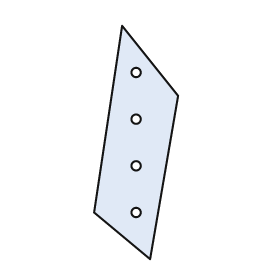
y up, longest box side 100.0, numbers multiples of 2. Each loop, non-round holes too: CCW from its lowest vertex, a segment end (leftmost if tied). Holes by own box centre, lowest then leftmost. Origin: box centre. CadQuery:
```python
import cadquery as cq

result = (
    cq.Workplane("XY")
    .moveTo(6.0, -50.0)
    .lineTo(18.0, 20.0)
    .lineTo(-6.0, 50.0)
    .lineTo(-18.0, -30.0)
    .close()
    .moveTo(0.0, -30.0)
    .circle(2.0)
    .moveTo(0.0, -10.0)
    .circle(2.0)
    .moveTo(0.0, 10.0)
    .circle(2.0)
    .moveTo(0.0, 30.0)
    .circle(2.0)
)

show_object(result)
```